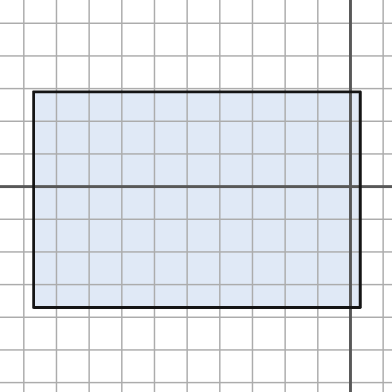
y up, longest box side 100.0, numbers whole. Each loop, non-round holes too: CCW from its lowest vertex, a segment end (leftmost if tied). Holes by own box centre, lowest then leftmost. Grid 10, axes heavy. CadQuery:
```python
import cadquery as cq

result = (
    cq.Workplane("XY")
    .moveTo(-97.0, -37.0)
    .lineTo(3.0, -37.0)
    .lineTo(3.0, 29.0)
    .lineTo(-97.0, 29.0)
    .close()
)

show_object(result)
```